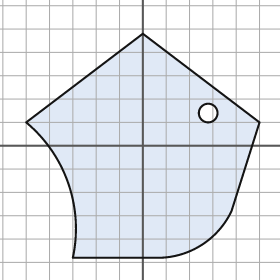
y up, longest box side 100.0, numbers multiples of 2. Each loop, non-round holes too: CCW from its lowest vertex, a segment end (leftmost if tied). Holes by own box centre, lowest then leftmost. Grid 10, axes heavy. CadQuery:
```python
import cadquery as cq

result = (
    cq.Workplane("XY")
    .moveTo(-30.0, -48.0)
    .lineTo(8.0, -48.0)
    .threePointArc((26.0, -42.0), (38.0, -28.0))
    .lineTo(50.0, 10.0)
    .lineTo(0.0, 48.0)
    .lineTo(-50.0, 10.0)
    .threePointArc((-32.0, -16.0), (-30.0, -48.0))
    .close()
    .moveTo(28.0, 14.0)
    .circle(4.0)
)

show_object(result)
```